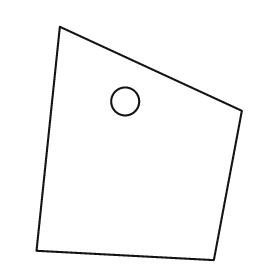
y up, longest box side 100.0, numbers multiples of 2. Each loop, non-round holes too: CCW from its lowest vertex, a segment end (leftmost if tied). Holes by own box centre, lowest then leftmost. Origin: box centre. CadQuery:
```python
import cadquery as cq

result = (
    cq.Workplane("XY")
    .moveTo(32.0, -50.0)
    .lineTo(44.0, 14.0)
    .lineTo(-34.0, 50.0)
    .lineTo(-44.0, -46.0)
    .close()
    .moveTo(-6.0, 18.0)
    .circle(6.0)
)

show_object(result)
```